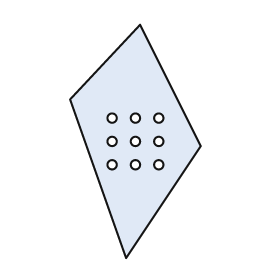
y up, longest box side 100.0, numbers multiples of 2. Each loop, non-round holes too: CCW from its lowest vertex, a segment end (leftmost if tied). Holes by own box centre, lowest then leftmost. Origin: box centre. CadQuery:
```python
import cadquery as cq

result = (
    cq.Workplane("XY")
    .moveTo(-4.0, -50.0)
    .lineTo(28.0, -2.0)
    .lineTo(2.0, 50.0)
    .lineTo(-28.0, 18.0)
    .close()
    .moveTo(-10.0, -10.0)
    .circle(2.0)
    .moveTo(0.0, -10.0)
    .circle(2.0)
    .moveTo(10.0, -10.0)
    .circle(2.0)
    .moveTo(-10.0, 0.0)
    .circle(2.0)
    .moveTo(0.0, 0.0)
    .circle(2.0)
    .moveTo(10.0, 0.0)
    .circle(2.0)
    .moveTo(-10.0, 10.0)
    .circle(2.0)
    .moveTo(0.0, 10.0)
    .circle(2.0)
    .moveTo(10.0, 10.0)
    .circle(2.0)
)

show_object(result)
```